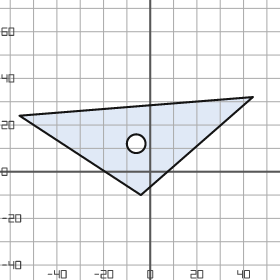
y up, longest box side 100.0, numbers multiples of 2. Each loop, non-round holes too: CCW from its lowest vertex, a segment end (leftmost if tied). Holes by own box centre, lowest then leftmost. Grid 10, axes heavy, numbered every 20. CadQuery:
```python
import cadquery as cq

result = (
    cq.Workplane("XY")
    .moveTo(-4.0, -10.0)
    .lineTo(44.0, 32.0)
    .lineTo(-56.0, 24.0)
    .close()
    .moveTo(-6.0, 12.0)
    .circle(4.0)
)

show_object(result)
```